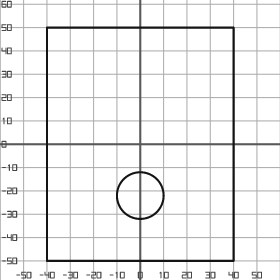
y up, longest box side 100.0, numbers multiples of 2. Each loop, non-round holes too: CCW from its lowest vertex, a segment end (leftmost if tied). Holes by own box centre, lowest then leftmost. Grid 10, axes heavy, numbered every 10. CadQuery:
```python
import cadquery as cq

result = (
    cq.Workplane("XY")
    .moveTo(-40.0, -50.0)
    .lineTo(40.0, -50.0)
    .lineTo(40.0, 50.0)
    .lineTo(-40.0, 50.0)
    .close()
    .moveTo(0.0, -22.0)
    .circle(10.0)
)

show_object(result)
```